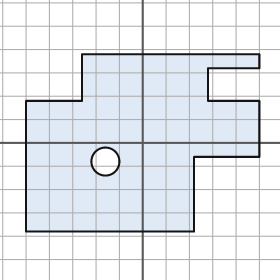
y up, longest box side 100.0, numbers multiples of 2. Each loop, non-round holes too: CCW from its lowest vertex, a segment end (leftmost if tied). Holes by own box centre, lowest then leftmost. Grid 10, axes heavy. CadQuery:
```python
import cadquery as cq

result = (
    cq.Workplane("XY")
    .moveTo(-50.0, -38.0)
    .lineTo(22.0, -38.0)
    .lineTo(22.0, -6.0)
    .lineTo(50.0, -6.0)
    .lineTo(50.0, 18.0)
    .lineTo(28.0, 18.0)
    .lineTo(28.0, 32.0)
    .lineTo(50.0, 32.0)
    .lineTo(50.0, 38.0)
    .lineTo(-26.0, 38.0)
    .lineTo(-26.0, 18.0)
    .lineTo(-50.0, 18.0)
    .close()
    .moveTo(-16.0, -8.0)
    .circle(6.0)
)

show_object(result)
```